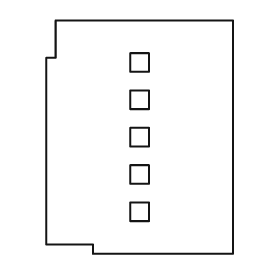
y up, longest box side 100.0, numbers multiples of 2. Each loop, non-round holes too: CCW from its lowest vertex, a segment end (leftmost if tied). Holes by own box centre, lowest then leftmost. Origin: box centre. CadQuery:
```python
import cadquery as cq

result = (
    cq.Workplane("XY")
    .moveTo(-20.0, -50.0)
    .lineTo(40.0, -50.0)
    .lineTo(40.0, 50.0)
    .lineTo(-36.0, 50.0)
    .lineTo(-36.0, 34.0)
    .lineTo(-40.0, 34.0)
    .lineTo(-40.0, -46.0)
    .lineTo(-20.0, -46.0)
    .close()
    .moveTo(-4.0, -36.0)
    .lineTo(4.0, -36.0)
    .lineTo(4.0, -28.0)
    .lineTo(-4.0, -28.0)
    .close()
    .moveTo(-4.0, -20.0)
    .lineTo(4.0, -20.0)
    .lineTo(4.0, -12.0)
    .lineTo(-4.0, -12.0)
    .close()
    .moveTo(-4.0, -4.0)
    .lineTo(4.0, -4.0)
    .lineTo(4.0, 4.0)
    .lineTo(-4.0, 4.0)
    .close()
    .moveTo(-4.0, 12.0)
    .lineTo(4.0, 12.0)
    .lineTo(4.0, 20.0)
    .lineTo(-4.0, 20.0)
    .close()
    .moveTo(-4.0, 28.0)
    .lineTo(4.0, 28.0)
    .lineTo(4.0, 36.0)
    .lineTo(-4.0, 36.0)
    .close()
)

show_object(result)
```